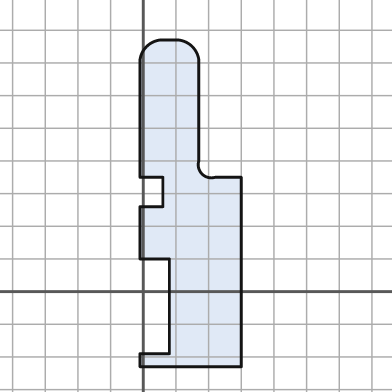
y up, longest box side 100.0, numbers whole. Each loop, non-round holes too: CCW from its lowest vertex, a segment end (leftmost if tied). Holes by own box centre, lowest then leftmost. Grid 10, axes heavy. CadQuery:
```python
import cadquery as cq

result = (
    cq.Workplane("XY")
    .moveTo(-1.0, -23.0)
    .lineTo(30.0, -23.0)
    .lineTo(30.0, 35.0)
    .lineTo(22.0, 35.0)
    .threePointArc((18.0, 36.0), (17.0, 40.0))
    .lineTo(17.0, 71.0)
    .threePointArc((15.0, 75.0), (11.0, 77.0))
    .lineTo(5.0, 77.0)
    .threePointArc((1.0, 75.0), (-1.0, 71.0))
    .lineTo(-1.0, 35.0)
    .lineTo(6.0, 35.0)
    .lineTo(6.0, 26.0)
    .lineTo(-1.0, 26.0)
    .lineTo(-1.0, 10.0)
    .lineTo(8.0, 10.0)
    .lineTo(8.0, -19.0)
    .lineTo(-1.0, -19.0)
    .close()
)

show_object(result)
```